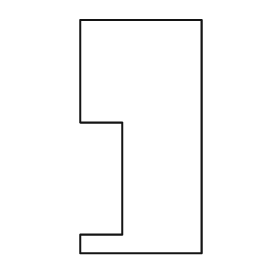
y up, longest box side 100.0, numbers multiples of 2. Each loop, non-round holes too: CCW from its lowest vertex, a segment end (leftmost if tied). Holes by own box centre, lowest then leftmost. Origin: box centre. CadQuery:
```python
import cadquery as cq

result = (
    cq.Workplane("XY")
    .moveTo(-26.0, -50.0)
    .lineTo(26.0, -50.0)
    .lineTo(26.0, 50.0)
    .lineTo(-26.0, 50.0)
    .lineTo(-26.0, 6.0)
    .lineTo(-8.0, 6.0)
    .lineTo(-8.0, -42.0)
    .lineTo(-26.0, -42.0)
    .close()
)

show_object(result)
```